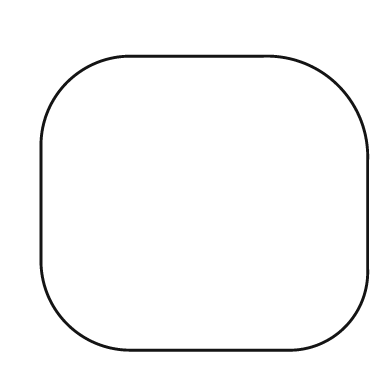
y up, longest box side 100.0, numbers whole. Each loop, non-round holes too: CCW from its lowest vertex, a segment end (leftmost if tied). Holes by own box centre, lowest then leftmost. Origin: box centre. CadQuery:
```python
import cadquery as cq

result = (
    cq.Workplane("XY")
    .moveTo(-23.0, -45.0)
    .lineTo(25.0, -45.0)
    .threePointArc((43.0, -38.0), (50.0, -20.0))
    .lineTo(50.0, 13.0)
    .threePointArc((41.0, 36.0), (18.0, 45.0))
    .lineTo(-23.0, 45.0)
    .threePointArc((-42.0, 37.0), (-50.0, 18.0))
    .lineTo(-50.0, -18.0)
    .threePointArc((-42.0, -37.0), (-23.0, -45.0))
    .close()
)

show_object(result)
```